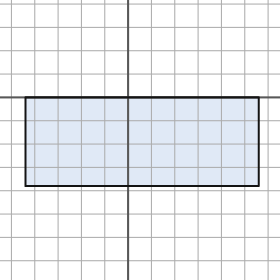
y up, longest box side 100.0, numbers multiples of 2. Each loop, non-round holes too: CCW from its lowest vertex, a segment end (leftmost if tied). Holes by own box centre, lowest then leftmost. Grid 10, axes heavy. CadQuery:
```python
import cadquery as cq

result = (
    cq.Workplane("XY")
    .moveTo(-44.0, -38.0)
    .lineTo(56.0, -38.0)
    .lineTo(56.0, 0.0)
    .lineTo(-44.0, 0.0)
    .close()
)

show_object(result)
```